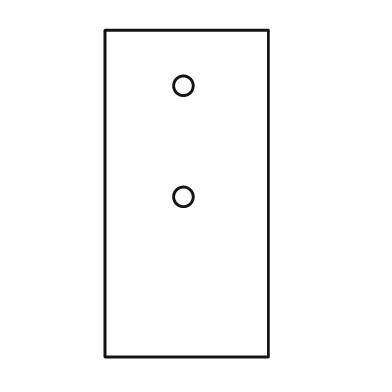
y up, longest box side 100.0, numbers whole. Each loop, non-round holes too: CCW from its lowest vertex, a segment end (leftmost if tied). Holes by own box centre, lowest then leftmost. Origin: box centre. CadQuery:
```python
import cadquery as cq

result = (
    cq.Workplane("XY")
    .moveTo(-25.0, -50.0)
    .lineTo(25.0, -50.0)
    .lineTo(25.0, 50.0)
    .lineTo(-25.0, 50.0)
    .close()
    .moveTo(-1.0, -1.0)
    .circle(3.0)
    .moveTo(-1.0, 33.0)
    .circle(3.0)
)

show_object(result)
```